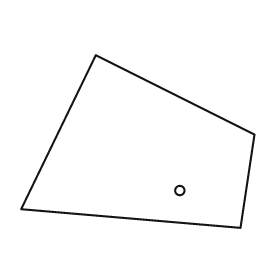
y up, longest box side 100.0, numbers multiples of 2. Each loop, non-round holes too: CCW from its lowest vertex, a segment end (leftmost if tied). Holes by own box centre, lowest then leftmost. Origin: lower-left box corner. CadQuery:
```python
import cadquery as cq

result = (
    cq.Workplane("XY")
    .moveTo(94.0, 0.0)
    .lineTo(100.0, 40.0)
    .lineTo(32.0, 74.0)
    .lineTo(0.0, 8.0)
    .close()
    .moveTo(68.0, 16.0)
    .circle(2.0)
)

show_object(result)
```